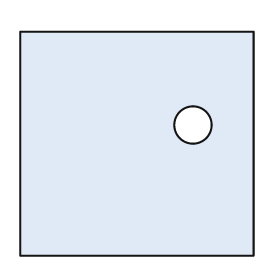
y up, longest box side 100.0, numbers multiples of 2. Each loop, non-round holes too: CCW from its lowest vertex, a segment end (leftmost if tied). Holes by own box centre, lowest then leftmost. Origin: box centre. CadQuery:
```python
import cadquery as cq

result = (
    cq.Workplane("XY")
    .moveTo(-50.0, -48.0)
    .lineTo(50.0, -48.0)
    .lineTo(50.0, 48.0)
    .lineTo(-50.0, 48.0)
    .close()
    .moveTo(24.0, 8.0)
    .circle(8.0)
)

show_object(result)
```